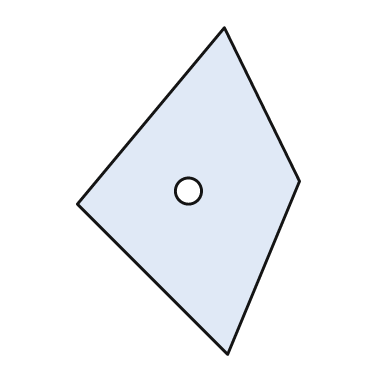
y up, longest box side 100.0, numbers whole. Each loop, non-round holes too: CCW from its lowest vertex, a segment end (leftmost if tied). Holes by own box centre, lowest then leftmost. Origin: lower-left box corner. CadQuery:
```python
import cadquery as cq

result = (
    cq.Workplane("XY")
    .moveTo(46.0, 0.0)
    .lineTo(68.0, 53.0)
    .lineTo(45.0, 100.0)
    .lineTo(0.0, 46.0)
    .close()
    .moveTo(34.0, 50.0)
    .circle(4.0)
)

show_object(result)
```